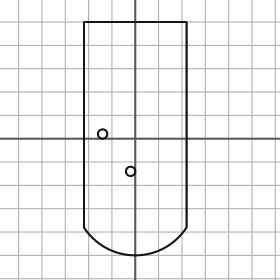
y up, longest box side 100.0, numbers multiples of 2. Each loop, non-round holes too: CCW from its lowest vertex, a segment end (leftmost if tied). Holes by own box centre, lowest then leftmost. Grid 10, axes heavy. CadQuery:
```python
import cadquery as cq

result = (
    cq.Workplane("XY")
    .moveTo(-22.0, -38.0)
    .threePointArc((0.0, -50.0), (22.0, -38.0))
    .lineTo(22.0, 50.0)
    .lineTo(-22.0, 50.0)
    .close()
    .moveTo(-2.0, -14.0)
    .circle(2.0)
    .moveTo(-14.0, 2.0)
    .circle(2.0)
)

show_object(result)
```